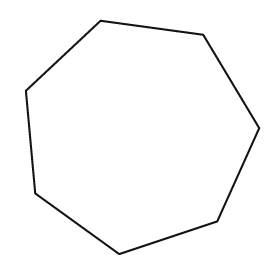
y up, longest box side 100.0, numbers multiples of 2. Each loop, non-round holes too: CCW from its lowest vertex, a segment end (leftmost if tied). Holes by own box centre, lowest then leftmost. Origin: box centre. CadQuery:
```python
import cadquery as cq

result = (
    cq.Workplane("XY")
    .moveTo(-10.0, -50.0)
    .lineTo(32.0, -36.0)
    .lineTo(50.0, 4.0)
    .lineTo(26.0, 44.0)
    .lineTo(-18.0, 50.0)
    .lineTo(-50.0, 20.0)
    .lineTo(-46.0, -24.0)
    .close()
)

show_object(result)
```